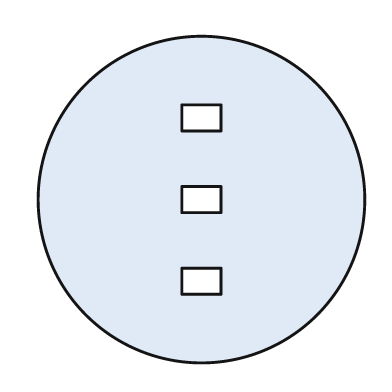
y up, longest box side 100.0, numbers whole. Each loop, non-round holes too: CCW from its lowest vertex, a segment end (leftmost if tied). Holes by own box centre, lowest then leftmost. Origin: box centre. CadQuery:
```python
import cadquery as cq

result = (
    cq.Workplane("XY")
    .moveTo(0.0, 0.0)
    .circle(50.0)
    .moveTo(-6.0, -29.0)
    .lineTo(6.0, -29.0)
    .lineTo(6.0, -21.0)
    .lineTo(-6.0, -21.0)
    .close()
    .moveTo(-6.0, -4.0)
    .lineTo(6.0, -4.0)
    .lineTo(6.0, 4.0)
    .lineTo(-6.0, 4.0)
    .close()
    .moveTo(-6.0, 21.0)
    .lineTo(6.0, 21.0)
    .lineTo(6.0, 29.0)
    .lineTo(-6.0, 29.0)
    .close()
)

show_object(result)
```